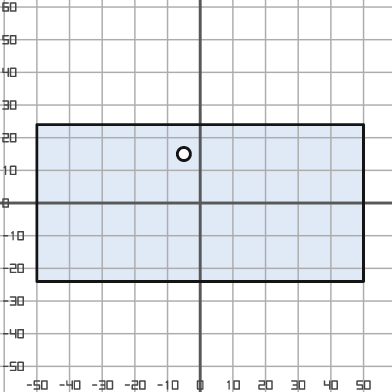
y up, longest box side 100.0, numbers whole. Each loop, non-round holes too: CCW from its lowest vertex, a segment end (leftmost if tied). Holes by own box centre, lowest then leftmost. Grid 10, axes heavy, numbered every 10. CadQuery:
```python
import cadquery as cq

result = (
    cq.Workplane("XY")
    .moveTo(-50.0, -24.0)
    .lineTo(50.0, -24.0)
    .lineTo(50.0, 24.0)
    .lineTo(-50.0, 24.0)
    .close()
    .moveTo(-5.0, 15.0)
    .circle(2.0)
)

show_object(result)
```